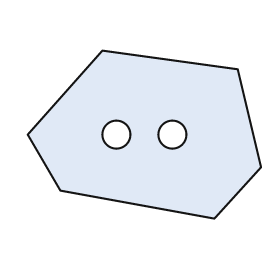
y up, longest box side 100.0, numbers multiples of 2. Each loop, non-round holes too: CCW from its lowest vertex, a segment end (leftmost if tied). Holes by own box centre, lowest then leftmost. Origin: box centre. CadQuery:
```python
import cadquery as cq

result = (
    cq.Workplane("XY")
    .moveTo(30.0, -36.0)
    .lineTo(50.0, -14.0)
    .lineTo(40.0, 28.0)
    .lineTo(-18.0, 36.0)
    .lineTo(-50.0, 0.0)
    .lineTo(-36.0, -24.0)
    .close()
    .moveTo(-12.0, 0.0)
    .circle(6.0)
    .moveTo(12.0, 0.0)
    .circle(6.0)
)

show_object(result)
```